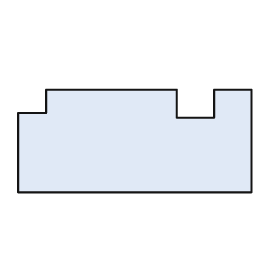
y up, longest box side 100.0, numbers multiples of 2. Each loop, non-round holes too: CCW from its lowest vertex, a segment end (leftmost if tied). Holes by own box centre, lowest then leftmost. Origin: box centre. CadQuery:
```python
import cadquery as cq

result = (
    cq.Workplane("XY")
    .moveTo(-50.0, -22.0)
    .lineTo(50.0, -22.0)
    .lineTo(50.0, 22.0)
    .lineTo(34.0, 22.0)
    .lineTo(34.0, 10.0)
    .lineTo(18.0, 10.0)
    .lineTo(18.0, 22.0)
    .lineTo(-38.0, 22.0)
    .lineTo(-38.0, 12.0)
    .lineTo(-50.0, 12.0)
    .close()
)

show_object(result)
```